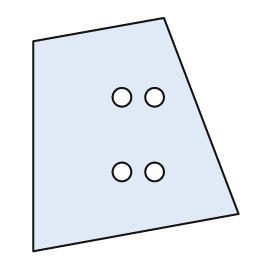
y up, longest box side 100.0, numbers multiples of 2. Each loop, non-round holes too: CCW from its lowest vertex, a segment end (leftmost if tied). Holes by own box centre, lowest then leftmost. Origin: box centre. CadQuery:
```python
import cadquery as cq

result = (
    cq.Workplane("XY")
    .moveTo(-44.0, -50.0)
    .lineTo(44.0, -34.0)
    .lineTo(12.0, 50.0)
    .lineTo(-44.0, 40.0)
    .close()
    .moveTo(-6.0, -16.0)
    .circle(4.0)
    .moveTo(8.0, -16.0)
    .circle(4.0)
    .moveTo(-6.0, 16.0)
    .circle(4.0)
    .moveTo(8.0, 16.0)
    .circle(4.0)
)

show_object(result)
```